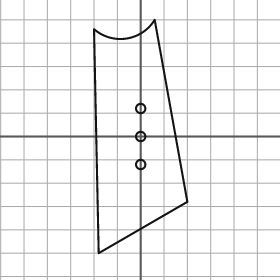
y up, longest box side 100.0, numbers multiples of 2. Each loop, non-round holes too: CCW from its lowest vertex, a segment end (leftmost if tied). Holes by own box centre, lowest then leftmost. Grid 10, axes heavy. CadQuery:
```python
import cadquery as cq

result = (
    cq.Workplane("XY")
    .moveTo(-18.0, -50.0)
    .lineTo(20.0, -28.0)
    .lineTo(6.0, 50.0)
    .threePointArc((-6.0, 42.0), (-20.0, 46.0))
    .close()
    .moveTo(0.0, -12.0)
    .circle(2.0)
    .moveTo(0.0, 0.0)
    .circle(2.0)
    .moveTo(0.0, 12.0)
    .circle(2.0)
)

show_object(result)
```